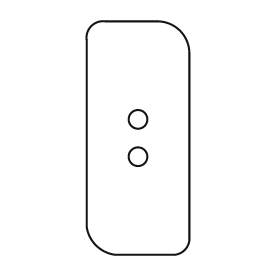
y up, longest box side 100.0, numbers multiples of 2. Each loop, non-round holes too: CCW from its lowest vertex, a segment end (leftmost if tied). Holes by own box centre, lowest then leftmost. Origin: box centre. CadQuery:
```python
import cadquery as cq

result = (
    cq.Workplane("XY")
    .moveTo(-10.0, -50.0)
    .lineTo(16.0, -50.0)
    .threePointArc((20.0, -48.0), (22.0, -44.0))
    .lineTo(22.0, 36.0)
    .threePointArc((18.0, 46.0), (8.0, 50.0))
    .lineTo(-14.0, 50.0)
    .threePointArc((-20.0, 48.0), (-22.0, 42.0))
    .lineTo(-22.0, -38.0)
    .threePointArc((-18.0, -46.0), (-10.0, -50.0))
    .close()
    .moveTo(0.0, -8.0)
    .circle(4.0)
    .moveTo(0.0, 8.0)
    .circle(4.0)
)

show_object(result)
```